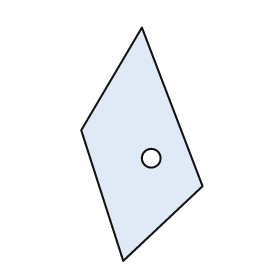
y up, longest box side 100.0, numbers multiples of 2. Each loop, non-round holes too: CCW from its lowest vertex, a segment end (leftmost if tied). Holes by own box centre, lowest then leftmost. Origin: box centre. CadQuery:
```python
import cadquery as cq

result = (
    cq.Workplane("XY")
    .moveTo(-8.0, -50.0)
    .lineTo(26.0, -18.0)
    .lineTo(0.0, 50.0)
    .lineTo(-26.0, 6.0)
    .close()
    .moveTo(4.0, -6.0)
    .circle(4.0)
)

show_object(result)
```